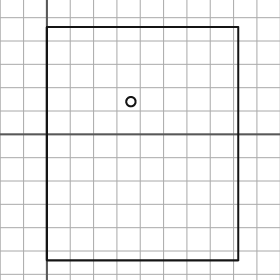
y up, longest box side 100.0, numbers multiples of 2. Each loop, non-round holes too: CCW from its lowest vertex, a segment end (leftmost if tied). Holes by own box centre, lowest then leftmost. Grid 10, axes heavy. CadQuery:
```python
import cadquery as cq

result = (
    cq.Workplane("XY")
    .moveTo(0.0, -54.0)
    .lineTo(82.0, -54.0)
    .lineTo(82.0, 46.0)
    .lineTo(0.0, 46.0)
    .close()
    .moveTo(36.0, 14.0)
    .circle(2.0)
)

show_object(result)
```